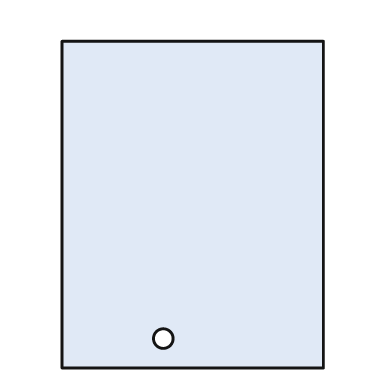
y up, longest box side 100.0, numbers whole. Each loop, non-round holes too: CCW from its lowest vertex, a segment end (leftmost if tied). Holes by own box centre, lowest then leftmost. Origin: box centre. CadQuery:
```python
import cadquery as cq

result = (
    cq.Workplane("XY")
    .moveTo(-40.0, -50.0)
    .lineTo(40.0, -50.0)
    .lineTo(40.0, 50.0)
    .lineTo(-40.0, 50.0)
    .close()
    .moveTo(-9.0, -41.0)
    .circle(3.0)
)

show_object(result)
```